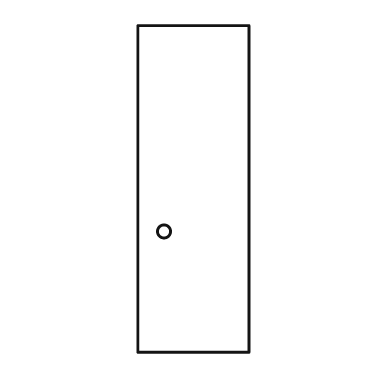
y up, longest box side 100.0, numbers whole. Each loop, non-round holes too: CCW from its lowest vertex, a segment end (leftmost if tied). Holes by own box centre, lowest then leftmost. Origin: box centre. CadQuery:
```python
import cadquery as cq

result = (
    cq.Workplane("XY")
    .moveTo(-17.0, -50.0)
    .lineTo(17.0, -50.0)
    .lineTo(17.0, 50.0)
    .lineTo(-17.0, 50.0)
    .close()
    .moveTo(-9.0, -13.0)
    .circle(2.0)
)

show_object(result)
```